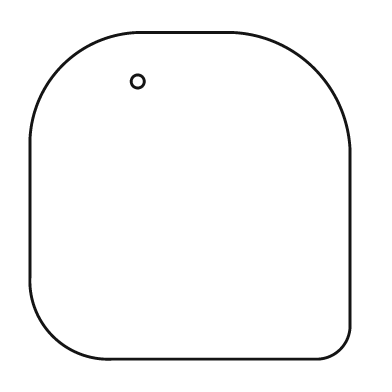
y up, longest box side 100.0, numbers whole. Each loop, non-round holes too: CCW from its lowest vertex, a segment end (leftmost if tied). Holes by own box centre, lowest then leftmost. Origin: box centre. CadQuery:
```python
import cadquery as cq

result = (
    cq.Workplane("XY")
    .moveTo(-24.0, -50.0)
    .lineTo(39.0, -50.0)
    .threePointArc((46.0, -47.0), (49.0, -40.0))
    .lineTo(49.0, 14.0)
    .threePointArc((38.0, 39.0), (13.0, 50.0))
    .lineTo(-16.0, 50.0)
    .threePointArc((-39.0, 40.0), (-49.0, 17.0))
    .lineTo(-49.0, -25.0)
    .threePointArc((-42.0, -43.0), (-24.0, -50.0))
    .close()
    .moveTo(-16.0, 35.0)
    .circle(2.0)
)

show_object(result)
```